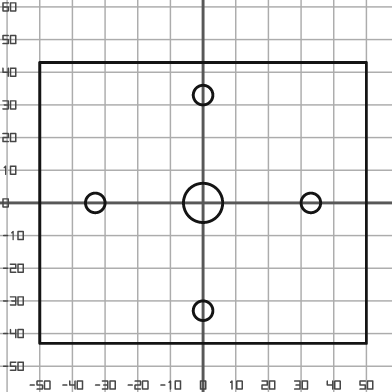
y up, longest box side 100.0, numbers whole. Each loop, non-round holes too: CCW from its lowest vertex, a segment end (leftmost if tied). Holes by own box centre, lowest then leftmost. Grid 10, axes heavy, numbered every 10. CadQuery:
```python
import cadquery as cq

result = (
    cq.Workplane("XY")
    .moveTo(-50.0, -43.0)
    .lineTo(50.0, -43.0)
    .lineTo(50.0, 43.0)
    .lineTo(-50.0, 43.0)
    .close()
    .moveTo(0.0, -33.0)
    .circle(3.0)
    .moveTo(-33.0, 0.0)
    .circle(3.0)
    .moveTo(0.0, 0.0)
    .circle(6.0)
    .moveTo(33.0, 0.0)
    .circle(3.0)
    .moveTo(0.0, 33.0)
    .circle(3.0)
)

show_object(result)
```